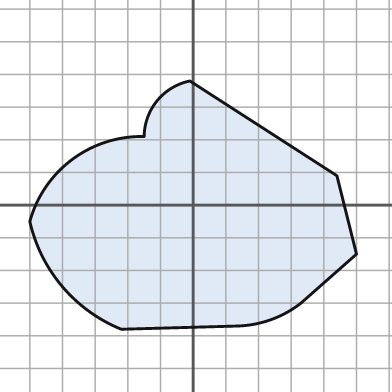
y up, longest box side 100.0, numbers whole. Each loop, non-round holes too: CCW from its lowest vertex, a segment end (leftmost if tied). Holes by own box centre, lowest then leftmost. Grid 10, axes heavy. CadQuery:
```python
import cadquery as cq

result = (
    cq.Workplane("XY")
    .moveTo(-22.0, -38.0)
    .lineTo(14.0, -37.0)
    .threePointArc((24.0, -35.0), (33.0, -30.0))
    .lineTo(50.0, -15.0)
    .lineTo(44.0, 9.0)
    .lineTo(-1.0, 38.0)
    .threePointArc((-11.0, 32.0), (-15.0, 21.0))
    .threePointArc((-37.0, 14.0), (-50.0, -5.0))
    .threePointArc((-40.0, -25.0), (-22.0, -38.0))
    .close()
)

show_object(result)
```